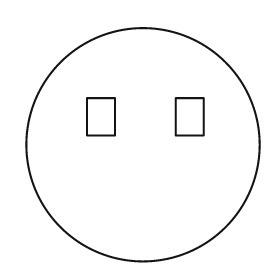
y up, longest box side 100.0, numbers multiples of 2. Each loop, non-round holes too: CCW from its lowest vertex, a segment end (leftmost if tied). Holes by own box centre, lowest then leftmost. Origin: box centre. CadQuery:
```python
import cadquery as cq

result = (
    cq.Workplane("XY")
    .moveTo(0.0, 0.0)
    .circle(50.0)
    .moveTo(-24.0, 4.0)
    .lineTo(-12.0, 4.0)
    .lineTo(-12.0, 20.0)
    .lineTo(-24.0, 20.0)
    .close()
    .moveTo(14.0, 4.0)
    .lineTo(26.0, 4.0)
    .lineTo(26.0, 20.0)
    .lineTo(14.0, 20.0)
    .close()
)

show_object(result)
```